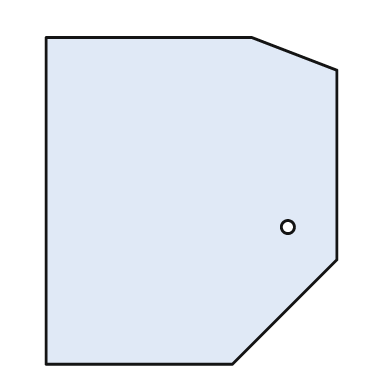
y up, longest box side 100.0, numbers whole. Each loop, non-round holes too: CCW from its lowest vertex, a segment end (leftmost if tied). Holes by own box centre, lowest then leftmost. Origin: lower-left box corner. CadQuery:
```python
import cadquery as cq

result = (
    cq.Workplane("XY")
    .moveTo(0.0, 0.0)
    .lineTo(57.0, 0.0)
    .lineTo(89.0, 32.0)
    .lineTo(89.0, 90.0)
    .lineTo(63.0, 100.0)
    .lineTo(0.0, 100.0)
    .close()
    .moveTo(74.0, 42.0)
    .circle(2.0)
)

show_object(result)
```